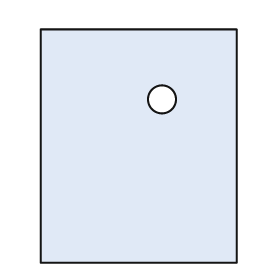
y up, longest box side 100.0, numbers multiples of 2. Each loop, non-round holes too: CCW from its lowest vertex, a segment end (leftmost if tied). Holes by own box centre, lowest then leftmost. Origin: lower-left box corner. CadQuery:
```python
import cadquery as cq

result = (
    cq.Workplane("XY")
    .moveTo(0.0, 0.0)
    .lineTo(84.0, 0.0)
    .lineTo(84.0, 100.0)
    .lineTo(0.0, 100.0)
    .close()
    .moveTo(52.0, 70.0)
    .circle(6.0)
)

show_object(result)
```